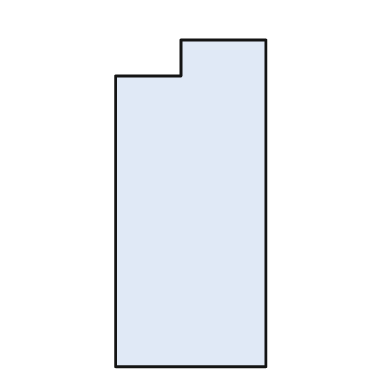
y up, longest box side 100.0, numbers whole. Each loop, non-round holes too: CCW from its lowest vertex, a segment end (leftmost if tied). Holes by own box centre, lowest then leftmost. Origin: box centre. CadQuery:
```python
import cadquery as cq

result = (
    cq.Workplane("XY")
    .moveTo(-23.0, -50.0)
    .lineTo(23.0, -50.0)
    .lineTo(23.0, 50.0)
    .lineTo(-3.0, 50.0)
    .lineTo(-3.0, 39.0)
    .lineTo(-23.0, 39.0)
    .close()
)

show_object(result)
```